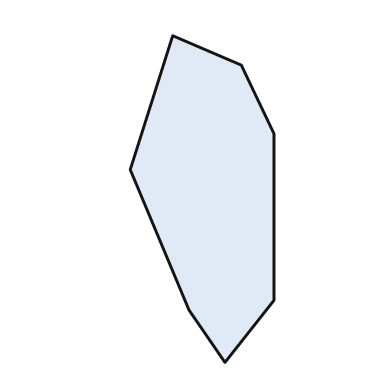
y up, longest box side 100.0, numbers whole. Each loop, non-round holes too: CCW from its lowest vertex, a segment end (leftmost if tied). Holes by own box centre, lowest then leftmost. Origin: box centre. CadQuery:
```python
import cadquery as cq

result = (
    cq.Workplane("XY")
    .moveTo(7.0, -50.0)
    .lineTo(22.0, -31.0)
    .lineTo(22.0, 20.0)
    .lineTo(12.0, 41.0)
    .lineTo(-9.0, 50.0)
    .lineTo(-22.0, 9.0)
    .lineTo(-4.0, -34.0)
    .close()
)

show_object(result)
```